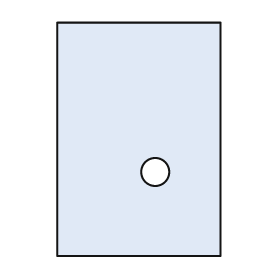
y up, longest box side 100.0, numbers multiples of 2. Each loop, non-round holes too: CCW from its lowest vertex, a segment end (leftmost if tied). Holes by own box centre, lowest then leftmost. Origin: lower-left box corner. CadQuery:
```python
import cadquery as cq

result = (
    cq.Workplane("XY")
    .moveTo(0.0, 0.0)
    .lineTo(70.0, 0.0)
    .lineTo(70.0, 100.0)
    .lineTo(0.0, 100.0)
    .close()
    .moveTo(42.0, 36.0)
    .circle(6.0)
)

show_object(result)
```